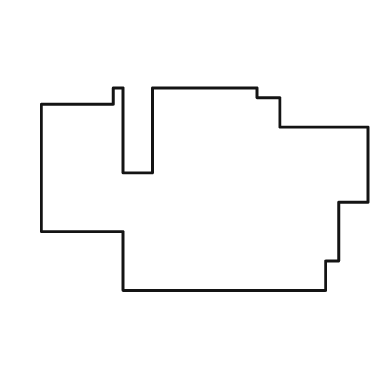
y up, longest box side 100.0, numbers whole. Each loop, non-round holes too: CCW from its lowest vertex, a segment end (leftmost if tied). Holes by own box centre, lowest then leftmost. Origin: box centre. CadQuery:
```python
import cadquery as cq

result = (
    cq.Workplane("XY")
    .moveTo(-25.0, -31.0)
    .lineTo(37.0, -31.0)
    .lineTo(37.0, -22.0)
    .lineTo(41.0, -22.0)
    .lineTo(41.0, -4.0)
    .lineTo(50.0, -4.0)
    .lineTo(50.0, 19.0)
    .lineTo(23.0, 19.0)
    .lineTo(23.0, 28.0)
    .lineTo(16.0, 28.0)
    .lineTo(16.0, 31.0)
    .lineTo(-16.0, 31.0)
    .lineTo(-16.0, 5.0)
    .lineTo(-25.0, 5.0)
    .lineTo(-25.0, 31.0)
    .lineTo(-28.0, 31.0)
    .lineTo(-28.0, 26.0)
    .lineTo(-50.0, 26.0)
    .lineTo(-50.0, -13.0)
    .lineTo(-25.0, -13.0)
    .close()
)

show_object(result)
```